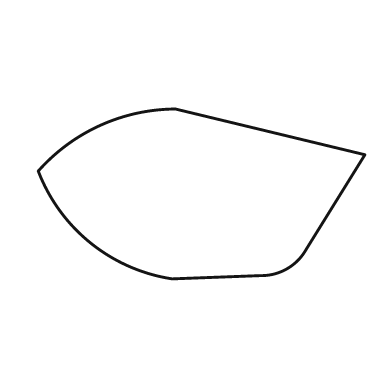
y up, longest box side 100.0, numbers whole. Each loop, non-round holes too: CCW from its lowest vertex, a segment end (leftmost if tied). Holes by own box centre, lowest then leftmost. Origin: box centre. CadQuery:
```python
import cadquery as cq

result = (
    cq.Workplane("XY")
    .moveTo(-9.0, -26.0)
    .lineTo(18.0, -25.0)
    .threePointArc((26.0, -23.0), (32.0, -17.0))
    .lineTo(50.0, 12.0)
    .lineTo(-8.0, 26.0)
    .threePointArc((-31.0, 21.0), (-50.0, 7.0))
    .threePointArc((-34.0, -15.0), (-9.0, -26.0))
    .close()
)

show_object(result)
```